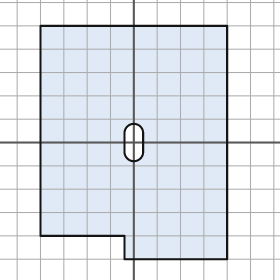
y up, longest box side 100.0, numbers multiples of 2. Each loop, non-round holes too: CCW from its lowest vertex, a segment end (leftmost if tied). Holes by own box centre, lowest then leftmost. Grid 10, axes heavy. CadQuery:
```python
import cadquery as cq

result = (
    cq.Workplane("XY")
    .moveTo(-4.0, -50.0)
    .lineTo(40.0, -50.0)
    .lineTo(40.0, 50.0)
    .lineTo(-40.0, 50.0)
    .lineTo(-40.0, -40.0)
    .lineTo(-4.0, -40.0)
    .close()
    .moveTo(-4.0, -4.0)
    .threePointArc((0.0, -8.0), (4.0, -4.0))
    .lineTo(4.0, 4.0)
    .threePointArc((0.0, 8.0), (-4.0, 4.0))
    .close()
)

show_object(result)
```